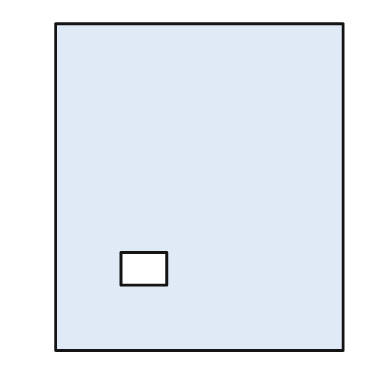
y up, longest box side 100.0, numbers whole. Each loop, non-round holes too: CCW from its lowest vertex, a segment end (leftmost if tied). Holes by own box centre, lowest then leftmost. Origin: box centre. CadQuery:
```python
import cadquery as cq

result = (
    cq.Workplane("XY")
    .moveTo(-44.0, -50.0)
    .lineTo(44.0, -50.0)
    .lineTo(44.0, 50.0)
    .lineTo(-44.0, 50.0)
    .close()
    .moveTo(-24.0, -30.0)
    .lineTo(-10.0, -30.0)
    .lineTo(-10.0, -20.0)
    .lineTo(-24.0, -20.0)
    .close()
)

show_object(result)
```